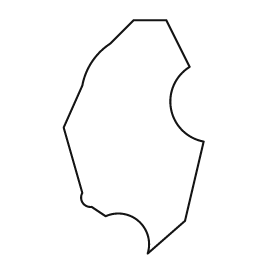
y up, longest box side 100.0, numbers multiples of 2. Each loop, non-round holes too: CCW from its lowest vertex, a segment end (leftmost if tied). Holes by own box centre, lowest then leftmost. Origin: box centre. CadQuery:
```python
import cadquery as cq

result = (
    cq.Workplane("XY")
    .moveTo(6.0, -50.0)
    .lineTo(22.0, -36.0)
    .lineTo(30.0, -2.0)
    .threePointArc((16.0, 12.0), (24.0, 30.0))
    .lineTo(14.0, 50.0)
    .lineTo(0.0, 50.0)
    .lineTo(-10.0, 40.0)
    .threePointArc((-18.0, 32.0), (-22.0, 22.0))
    .lineTo(-30.0, 4.0)
    .lineTo(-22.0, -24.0)
    .threePointArc((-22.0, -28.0), (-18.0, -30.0))
    .lineTo(-12.0, -34.0)
    .threePointArc((2.0, -36.0), (6.0, -50.0))
    .close()
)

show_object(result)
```